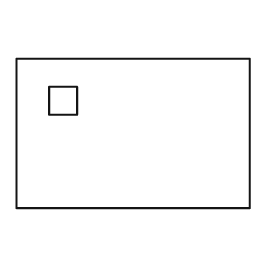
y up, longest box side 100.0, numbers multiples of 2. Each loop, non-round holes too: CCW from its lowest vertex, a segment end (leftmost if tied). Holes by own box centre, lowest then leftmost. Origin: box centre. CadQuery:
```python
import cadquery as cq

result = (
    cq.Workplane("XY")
    .moveTo(-50.0, -32.0)
    .lineTo(50.0, -32.0)
    .lineTo(50.0, 32.0)
    .lineTo(-50.0, 32.0)
    .close()
    .moveTo(-36.0, 8.0)
    .lineTo(-24.0, 8.0)
    .lineTo(-24.0, 20.0)
    .lineTo(-36.0, 20.0)
    .close()
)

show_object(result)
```